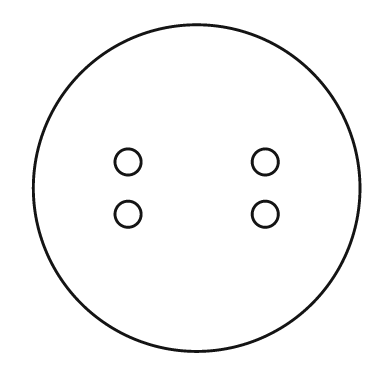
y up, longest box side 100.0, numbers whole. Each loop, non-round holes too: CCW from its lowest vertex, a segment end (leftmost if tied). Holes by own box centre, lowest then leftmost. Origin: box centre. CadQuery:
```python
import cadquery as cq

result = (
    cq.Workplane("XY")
    .moveTo(0.0, 0.0)
    .circle(50.0)
    .moveTo(-21.0, -8.0)
    .circle(4.0)
    .moveTo(21.0, -8.0)
    .circle(4.0)
    .moveTo(-21.0, 8.0)
    .circle(4.0)
    .moveTo(21.0, 8.0)
    .circle(4.0)
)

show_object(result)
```